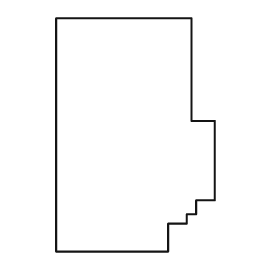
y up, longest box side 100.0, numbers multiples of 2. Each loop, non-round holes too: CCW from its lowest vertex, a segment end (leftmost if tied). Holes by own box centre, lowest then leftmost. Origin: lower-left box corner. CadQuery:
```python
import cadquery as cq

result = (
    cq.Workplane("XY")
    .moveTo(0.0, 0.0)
    .lineTo(48.0, 0.0)
    .lineTo(48.0, 12.0)
    .lineTo(56.0, 12.0)
    .lineTo(56.0, 16.0)
    .lineTo(60.0, 16.0)
    .lineTo(60.0, 22.0)
    .lineTo(68.0, 22.0)
    .lineTo(68.0, 56.0)
    .lineTo(58.0, 56.0)
    .lineTo(58.0, 100.0)
    .lineTo(0.0, 100.0)
    .close()
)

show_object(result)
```